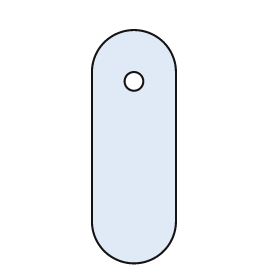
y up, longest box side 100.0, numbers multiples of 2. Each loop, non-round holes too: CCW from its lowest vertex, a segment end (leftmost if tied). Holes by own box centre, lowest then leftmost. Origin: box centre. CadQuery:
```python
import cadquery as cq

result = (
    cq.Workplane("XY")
    .moveTo(-18.0, -32.0)
    .threePointArc((0.0, -50.0), (18.0, -32.0))
    .lineTo(18.0, 32.0)
    .threePointArc((0.0, 50.0), (-18.0, 32.0))
    .close()
    .moveTo(0.0, 28.0)
    .circle(4.0)
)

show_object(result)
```